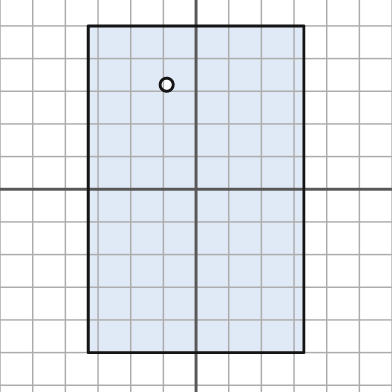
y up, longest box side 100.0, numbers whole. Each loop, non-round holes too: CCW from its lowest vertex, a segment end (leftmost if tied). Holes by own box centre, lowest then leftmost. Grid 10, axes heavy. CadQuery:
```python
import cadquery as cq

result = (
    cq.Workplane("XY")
    .moveTo(-33.0, -50.0)
    .lineTo(33.0, -50.0)
    .lineTo(33.0, 50.0)
    .lineTo(-33.0, 50.0)
    .close()
    .moveTo(-9.0, 32.0)
    .circle(2.0)
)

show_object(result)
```